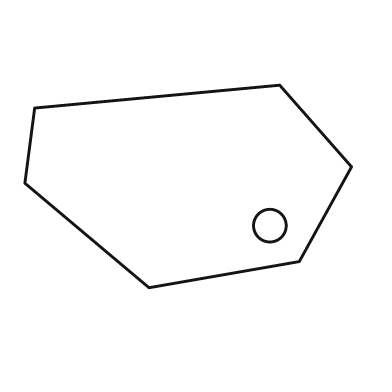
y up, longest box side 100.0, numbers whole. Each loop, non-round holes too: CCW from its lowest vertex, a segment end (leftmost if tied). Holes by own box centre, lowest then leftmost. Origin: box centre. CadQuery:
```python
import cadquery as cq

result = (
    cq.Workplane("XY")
    .moveTo(-12.0, -31.0)
    .lineTo(34.0, -23.0)
    .lineTo(50.0, 6.0)
    .lineTo(28.0, 31.0)
    .lineTo(-47.0, 24.0)
    .lineTo(-50.0, 1.0)
    .close()
    .moveTo(25.0, -12.0)
    .circle(5.0)
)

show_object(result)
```